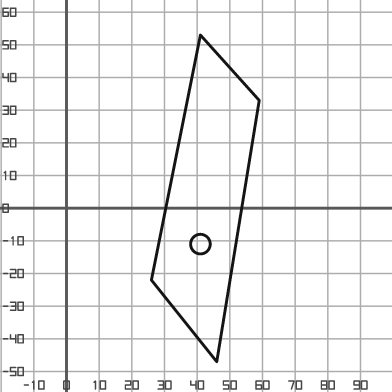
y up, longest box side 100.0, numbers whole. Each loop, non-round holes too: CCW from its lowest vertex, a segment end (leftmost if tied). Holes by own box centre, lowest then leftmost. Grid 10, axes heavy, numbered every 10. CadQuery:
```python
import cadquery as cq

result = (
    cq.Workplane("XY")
    .moveTo(46.0, -47.0)
    .lineTo(59.0, 33.0)
    .lineTo(41.0, 53.0)
    .lineTo(26.0, -22.0)
    .close()
    .moveTo(41.0, -11.0)
    .circle(3.0)
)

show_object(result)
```